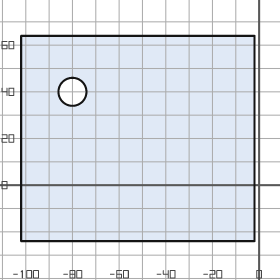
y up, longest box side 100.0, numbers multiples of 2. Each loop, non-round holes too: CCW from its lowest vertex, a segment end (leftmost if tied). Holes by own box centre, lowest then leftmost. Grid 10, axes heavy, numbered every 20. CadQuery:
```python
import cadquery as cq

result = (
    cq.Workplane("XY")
    .moveTo(-102.0, -24.0)
    .lineTo(-2.0, -24.0)
    .lineTo(-2.0, 64.0)
    .lineTo(-102.0, 64.0)
    .close()
    .moveTo(-80.0, 40.0)
    .circle(6.0)
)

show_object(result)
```